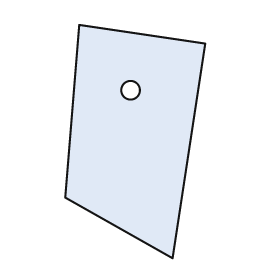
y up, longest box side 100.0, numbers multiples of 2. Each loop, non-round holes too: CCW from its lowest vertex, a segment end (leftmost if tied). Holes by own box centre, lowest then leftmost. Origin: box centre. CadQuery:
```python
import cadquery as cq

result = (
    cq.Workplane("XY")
    .moveTo(16.0, -50.0)
    .lineTo(30.0, 42.0)
    .lineTo(-24.0, 50.0)
    .lineTo(-30.0, -24.0)
    .close()
    .moveTo(-2.0, 22.0)
    .circle(4.0)
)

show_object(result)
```